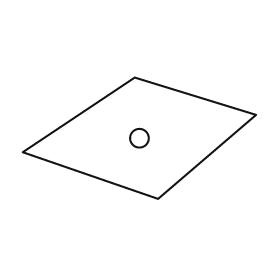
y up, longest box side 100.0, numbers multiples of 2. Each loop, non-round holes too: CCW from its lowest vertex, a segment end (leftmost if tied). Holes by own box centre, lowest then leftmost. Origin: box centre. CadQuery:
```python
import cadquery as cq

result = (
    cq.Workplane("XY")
    .moveTo(8.0, -26.0)
    .lineTo(50.0, 10.0)
    .lineTo(-2.0, 26.0)
    .lineTo(-50.0, -6.0)
    .close()
    .moveTo(0.0, 0.0)
    .circle(4.0)
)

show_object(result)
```